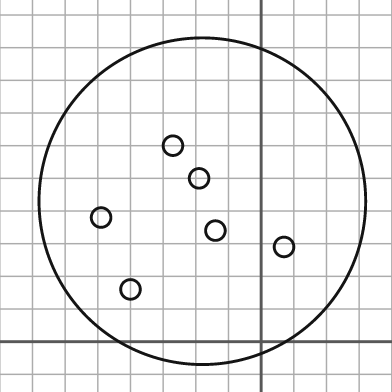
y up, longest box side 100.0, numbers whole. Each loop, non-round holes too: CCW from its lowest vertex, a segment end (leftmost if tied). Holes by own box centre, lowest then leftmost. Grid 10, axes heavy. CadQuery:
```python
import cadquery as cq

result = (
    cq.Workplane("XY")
    .moveTo(-18.0, 43.0)
    .circle(50.0)
    .moveTo(-40.0, 16.0)
    .circle(3.0)
    .moveTo(7.0, 29.0)
    .circle(3.0)
    .moveTo(-14.0, 34.0)
    .circle(3.0)
    .moveTo(-49.0, 38.0)
    .circle(3.0)
    .moveTo(-19.0, 50.0)
    .circle(3.0)
    .moveTo(-27.0, 60.0)
    .circle(3.0)
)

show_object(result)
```